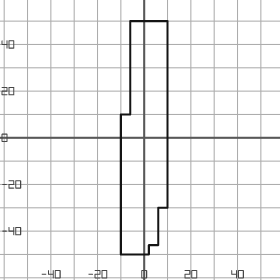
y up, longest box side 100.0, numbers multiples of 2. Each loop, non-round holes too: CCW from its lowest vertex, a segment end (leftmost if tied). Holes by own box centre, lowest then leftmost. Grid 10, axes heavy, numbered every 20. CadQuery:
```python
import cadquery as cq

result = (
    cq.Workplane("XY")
    .moveTo(-10.0, -50.0)
    .lineTo(2.0, -50.0)
    .lineTo(2.0, -46.0)
    .lineTo(6.0, -46.0)
    .lineTo(6.0, -30.0)
    .lineTo(10.0, -30.0)
    .lineTo(10.0, 50.0)
    .lineTo(-6.0, 50.0)
    .lineTo(-6.0, 10.0)
    .lineTo(-10.0, 10.0)
    .close()
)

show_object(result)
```